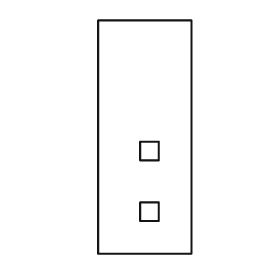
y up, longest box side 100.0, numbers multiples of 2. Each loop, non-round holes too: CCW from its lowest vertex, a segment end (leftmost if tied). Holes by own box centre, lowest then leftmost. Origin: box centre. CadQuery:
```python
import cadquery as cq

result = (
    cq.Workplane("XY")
    .moveTo(-20.0, -50.0)
    .lineTo(20.0, -50.0)
    .lineTo(20.0, 50.0)
    .lineTo(-20.0, 50.0)
    .close()
    .moveTo(-2.0, -36.0)
    .lineTo(6.0, -36.0)
    .lineTo(6.0, -28.0)
    .lineTo(-2.0, -28.0)
    .close()
    .moveTo(-2.0, -10.0)
    .lineTo(6.0, -10.0)
    .lineTo(6.0, -2.0)
    .lineTo(-2.0, -2.0)
    .close()
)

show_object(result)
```